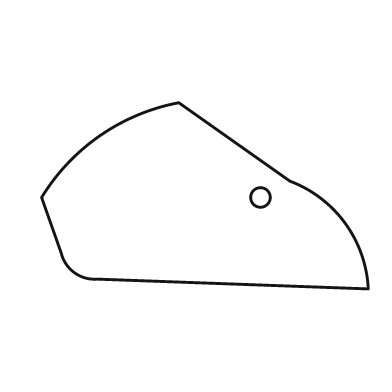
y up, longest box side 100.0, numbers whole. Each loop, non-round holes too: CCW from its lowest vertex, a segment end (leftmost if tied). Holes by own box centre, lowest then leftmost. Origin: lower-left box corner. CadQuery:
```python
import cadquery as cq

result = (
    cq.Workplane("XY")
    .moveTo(100.0, 0.0)
    .threePointArc((93.0, 20.0), (76.0, 33.0))
    .lineTo(42.0, 57.0)
    .threePointArc((18.0, 47.0), (0.0, 28.0))
    .lineTo(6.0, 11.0)
    .threePointArc((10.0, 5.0), (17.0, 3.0))
    .close()
    .moveTo(67.0, 28.0)
    .circle(3.0)
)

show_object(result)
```